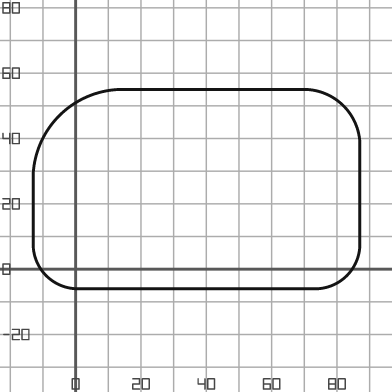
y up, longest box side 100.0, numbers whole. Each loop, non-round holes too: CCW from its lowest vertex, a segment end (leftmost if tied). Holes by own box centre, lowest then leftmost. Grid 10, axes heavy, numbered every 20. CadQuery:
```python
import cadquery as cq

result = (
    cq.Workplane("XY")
    .moveTo(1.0, -6.0)
    .lineTo(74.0, -6.0)
    .threePointArc((83.0, -2.0), (87.0, 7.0))
    .lineTo(87.0, 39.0)
    .threePointArc((82.0, 50.0), (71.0, 55.0))
    .lineTo(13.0, 55.0)
    .threePointArc((-5.0, 47.0), (-13.0, 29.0))
    .lineTo(-13.0, 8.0)
    .threePointArc((-9.0, -2.0), (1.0, -6.0))
    .close()
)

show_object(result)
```